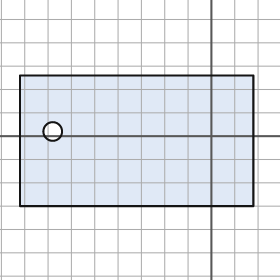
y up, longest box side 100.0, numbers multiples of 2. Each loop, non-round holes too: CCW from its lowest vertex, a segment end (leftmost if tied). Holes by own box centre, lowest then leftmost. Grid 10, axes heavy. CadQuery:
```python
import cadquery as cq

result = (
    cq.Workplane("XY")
    .moveTo(-82.0, -30.0)
    .lineTo(18.0, -30.0)
    .lineTo(18.0, 26.0)
    .lineTo(-82.0, 26.0)
    .close()
    .moveTo(-68.0, 2.0)
    .circle(4.0)
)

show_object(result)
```